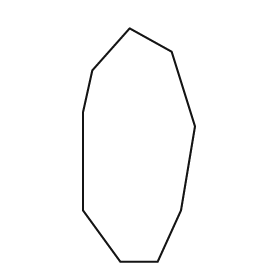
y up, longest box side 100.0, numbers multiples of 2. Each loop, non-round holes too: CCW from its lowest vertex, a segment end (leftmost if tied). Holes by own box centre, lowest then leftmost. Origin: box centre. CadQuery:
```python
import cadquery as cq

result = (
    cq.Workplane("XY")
    .moveTo(-8.0, -50.0)
    .lineTo(8.0, -50.0)
    .lineTo(18.0, -28.0)
    .lineTo(24.0, 8.0)
    .lineTo(14.0, 40.0)
    .lineTo(-4.0, 50.0)
    .lineTo(-20.0, 32.0)
    .lineTo(-24.0, 14.0)
    .lineTo(-24.0, -28.0)
    .close()
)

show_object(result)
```